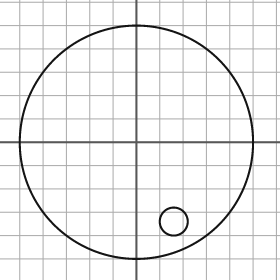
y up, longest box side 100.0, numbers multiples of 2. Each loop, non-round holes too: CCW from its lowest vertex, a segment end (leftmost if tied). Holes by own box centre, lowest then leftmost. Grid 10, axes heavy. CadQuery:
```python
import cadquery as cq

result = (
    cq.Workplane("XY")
    .moveTo(0.0, 0.0)
    .circle(50.0)
    .moveTo(16.0, -34.0)
    .circle(6.0)
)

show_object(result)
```